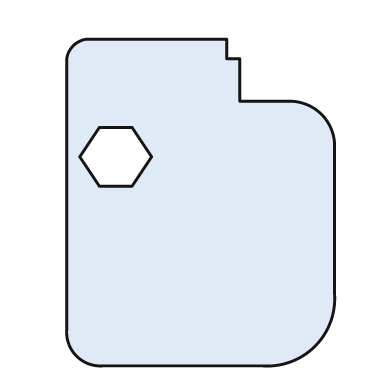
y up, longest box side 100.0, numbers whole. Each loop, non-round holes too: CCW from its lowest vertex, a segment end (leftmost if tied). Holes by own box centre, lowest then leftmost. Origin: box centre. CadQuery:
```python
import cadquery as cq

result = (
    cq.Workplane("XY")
    .moveTo(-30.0, -50.0)
    .lineTo(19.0, -50.0)
    .threePointArc((35.0, -44.0), (41.0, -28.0))
    .lineTo(41.0, 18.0)
    .threePointArc((37.0, 27.0), (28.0, 31.0))
    .lineTo(12.0, 31.0)
    .lineTo(12.0, 44.0)
    .lineTo(8.0, 44.0)
    .lineTo(8.0, 50.0)
    .lineTo(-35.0, 50.0)
    .threePointArc((-39.0, 48.0), (-41.0, 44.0))
    .lineTo(-41.0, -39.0)
    .threePointArc((-38.0, -47.0), (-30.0, -50.0))
    .close()
    .moveTo(-31.0, 5.0)
    .lineTo(-21.0, 5.0)
    .lineTo(-15.0, 14.0)
    .lineTo(-21.0, 23.0)
    .lineTo(-31.0, 23.0)
    .lineTo(-37.0, 14.0)
    .close()
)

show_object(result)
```